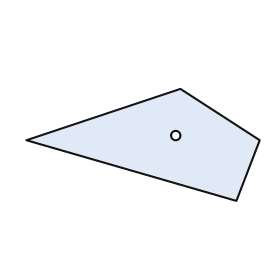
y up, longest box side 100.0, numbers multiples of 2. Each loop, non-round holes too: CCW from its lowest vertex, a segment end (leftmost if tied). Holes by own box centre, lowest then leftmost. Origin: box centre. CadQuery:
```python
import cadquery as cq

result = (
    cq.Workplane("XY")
    .moveTo(40.0, -24.0)
    .lineTo(50.0, 2.0)
    .lineTo(16.0, 24.0)
    .lineTo(-50.0, 2.0)
    .close()
    .moveTo(14.0, 4.0)
    .circle(2.0)
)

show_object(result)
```